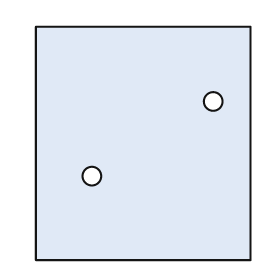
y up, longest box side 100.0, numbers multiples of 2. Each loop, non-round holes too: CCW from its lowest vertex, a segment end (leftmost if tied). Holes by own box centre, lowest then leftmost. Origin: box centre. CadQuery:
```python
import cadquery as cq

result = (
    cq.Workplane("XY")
    .moveTo(-46.0, -50.0)
    .lineTo(46.0, -50.0)
    .lineTo(46.0, 50.0)
    .lineTo(-46.0, 50.0)
    .close()
    .moveTo(-22.0, -14.0)
    .circle(4.0)
    .moveTo(30.0, 18.0)
    .circle(4.0)
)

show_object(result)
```